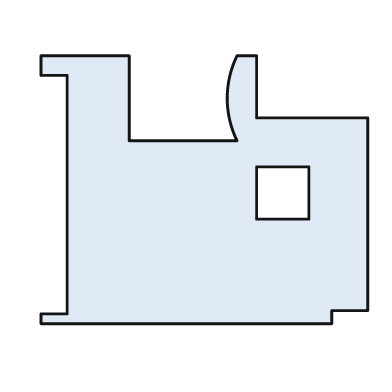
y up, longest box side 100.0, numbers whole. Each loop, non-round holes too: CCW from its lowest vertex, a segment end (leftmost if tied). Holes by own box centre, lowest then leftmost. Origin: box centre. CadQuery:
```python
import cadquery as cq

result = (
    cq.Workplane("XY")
    .moveTo(-50.0, -41.0)
    .lineTo(39.0, -41.0)
    .lineTo(39.0, -37.0)
    .lineTo(50.0, -37.0)
    .lineTo(50.0, 22.0)
    .lineTo(16.0, 22.0)
    .lineTo(16.0, 41.0)
    .lineTo(10.0, 41.0)
    .threePointArc((7.0, 28.0), (10.0, 15.0))
    .lineTo(-23.0, 15.0)
    .lineTo(-23.0, 41.0)
    .lineTo(-50.0, 41.0)
    .lineTo(-50.0, 35.0)
    .lineTo(-42.0, 35.0)
    .lineTo(-42.0, -38.0)
    .lineTo(-50.0, -38.0)
    .close()
    .moveTo(16.0, -9.0)
    .lineTo(32.0, -9.0)
    .lineTo(32.0, 7.0)
    .lineTo(16.0, 7.0)
    .close()
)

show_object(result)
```